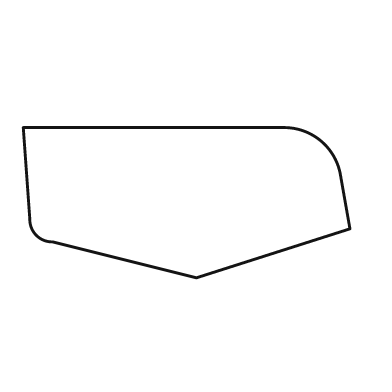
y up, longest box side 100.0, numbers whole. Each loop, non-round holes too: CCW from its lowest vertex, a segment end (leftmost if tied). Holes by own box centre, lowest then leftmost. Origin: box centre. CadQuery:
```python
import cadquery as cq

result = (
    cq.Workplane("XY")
    .moveTo(3.0, -23.0)
    .lineTo(50.0, -8.0)
    .lineTo(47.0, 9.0)
    .threePointArc((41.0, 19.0), (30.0, 23.0))
    .lineTo(-50.0, 23.0)
    .lineTo(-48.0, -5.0)
    .threePointArc((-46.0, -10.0), (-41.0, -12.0))
    .close()
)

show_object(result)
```